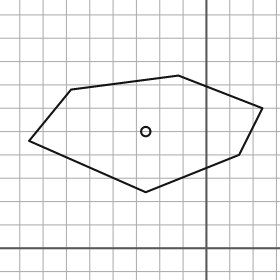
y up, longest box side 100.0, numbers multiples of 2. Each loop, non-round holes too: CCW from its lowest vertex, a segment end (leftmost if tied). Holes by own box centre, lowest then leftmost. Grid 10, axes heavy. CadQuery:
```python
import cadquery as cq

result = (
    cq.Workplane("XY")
    .moveTo(-26.0, 24.0)
    .lineTo(14.0, 40.0)
    .lineTo(24.0, 60.0)
    .lineTo(-12.0, 74.0)
    .lineTo(-58.0, 68.0)
    .lineTo(-76.0, 46.0)
    .close()
    .moveTo(-26.0, 50.0)
    .circle(2.0)
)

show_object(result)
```